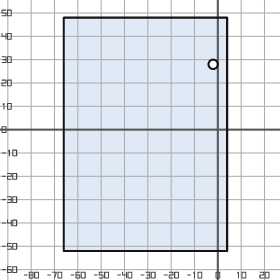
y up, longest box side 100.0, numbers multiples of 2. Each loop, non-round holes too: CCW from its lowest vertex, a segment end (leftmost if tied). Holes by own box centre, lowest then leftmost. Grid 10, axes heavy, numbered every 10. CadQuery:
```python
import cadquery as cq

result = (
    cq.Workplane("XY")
    .moveTo(-66.0, -52.0)
    .lineTo(4.0, -52.0)
    .lineTo(4.0, 48.0)
    .lineTo(-66.0, 48.0)
    .close()
    .moveTo(-2.0, 28.0)
    .circle(2.0)
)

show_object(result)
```